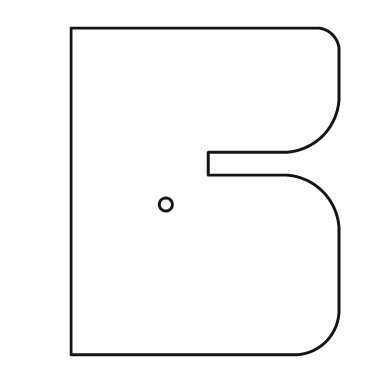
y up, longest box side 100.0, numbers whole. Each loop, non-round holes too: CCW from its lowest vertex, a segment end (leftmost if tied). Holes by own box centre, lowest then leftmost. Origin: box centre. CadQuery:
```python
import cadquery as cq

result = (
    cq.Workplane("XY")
    .moveTo(-41.0, -50.0)
    .lineTo(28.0, -50.0)
    .threePointArc((37.0, -46.0), (41.0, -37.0))
    .lineTo(41.0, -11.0)
    .threePointArc((36.0, 0.0), (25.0, 5.0))
    .lineTo(1.0, 5.0)
    .lineTo(1.0, 12.0)
    .lineTo(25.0, 12.0)
    .threePointArc((36.0, 17.0), (41.0, 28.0))
    .lineTo(41.0, 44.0)
    .threePointArc((39.0, 48.0), (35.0, 50.0))
    .lineTo(-41.0, 50.0)
    .close()
    .moveTo(-12.0, -4.0)
    .circle(2.0)
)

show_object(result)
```